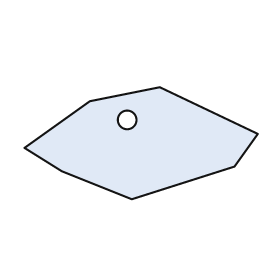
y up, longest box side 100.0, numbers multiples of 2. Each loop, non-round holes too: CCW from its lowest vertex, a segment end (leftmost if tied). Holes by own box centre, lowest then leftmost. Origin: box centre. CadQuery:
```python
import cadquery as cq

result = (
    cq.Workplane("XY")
    .moveTo(-4.0, -24.0)
    .lineTo(40.0, -10.0)
    .lineTo(50.0, 4.0)
    .lineTo(8.0, 24.0)
    .lineTo(-22.0, 18.0)
    .lineTo(-50.0, -2.0)
    .lineTo(-34.0, -12.0)
    .close()
    .moveTo(-6.0, 10.0)
    .circle(4.0)
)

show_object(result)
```